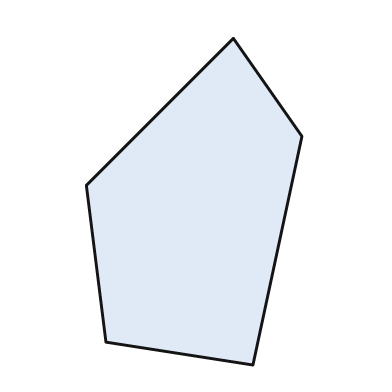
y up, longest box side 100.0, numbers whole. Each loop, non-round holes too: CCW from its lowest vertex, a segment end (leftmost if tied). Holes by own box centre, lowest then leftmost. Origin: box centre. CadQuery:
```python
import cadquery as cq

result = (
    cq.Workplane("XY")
    .moveTo(18.0, -50.0)
    .lineTo(33.0, 20.0)
    .lineTo(12.0, 50.0)
    .lineTo(-33.0, 5.0)
    .lineTo(-27.0, -43.0)
    .close()
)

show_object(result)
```